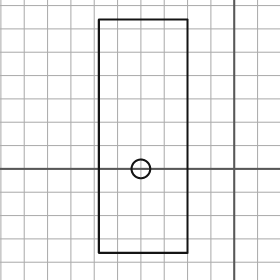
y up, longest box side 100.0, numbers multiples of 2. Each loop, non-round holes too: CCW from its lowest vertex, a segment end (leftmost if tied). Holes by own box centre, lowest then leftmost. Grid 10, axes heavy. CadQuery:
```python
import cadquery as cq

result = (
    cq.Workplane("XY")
    .moveTo(-58.0, -36.0)
    .lineTo(-20.0, -36.0)
    .lineTo(-20.0, 64.0)
    .lineTo(-58.0, 64.0)
    .close()
    .moveTo(-40.0, 0.0)
    .circle(4.0)
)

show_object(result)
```